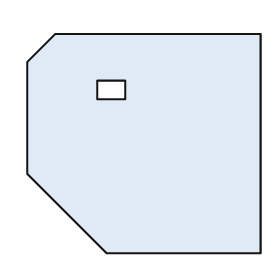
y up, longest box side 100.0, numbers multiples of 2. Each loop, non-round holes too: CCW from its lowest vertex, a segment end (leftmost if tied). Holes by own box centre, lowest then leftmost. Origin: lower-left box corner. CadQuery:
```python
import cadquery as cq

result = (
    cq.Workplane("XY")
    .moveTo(34.0, 0.0)
    .lineTo(100.0, 0.0)
    .lineTo(100.0, 94.0)
    .lineTo(12.0, 94.0)
    .lineTo(0.0, 82.0)
    .lineTo(0.0, 34.0)
    .close()
    .moveTo(30.0, 66.0)
    .lineTo(42.0, 66.0)
    .lineTo(42.0, 74.0)
    .lineTo(30.0, 74.0)
    .close()
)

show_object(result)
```